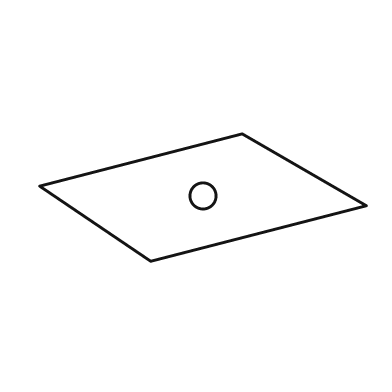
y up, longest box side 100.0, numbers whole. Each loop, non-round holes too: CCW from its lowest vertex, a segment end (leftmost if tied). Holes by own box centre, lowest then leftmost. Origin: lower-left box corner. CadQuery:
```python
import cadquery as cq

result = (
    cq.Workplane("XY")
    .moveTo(34.0, 0.0)
    .lineTo(100.0, 17.0)
    .lineTo(62.0, 39.0)
    .lineTo(0.0, 23.0)
    .close()
    .moveTo(50.0, 20.0)
    .circle(4.0)
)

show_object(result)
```